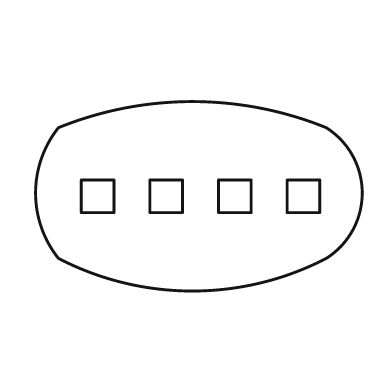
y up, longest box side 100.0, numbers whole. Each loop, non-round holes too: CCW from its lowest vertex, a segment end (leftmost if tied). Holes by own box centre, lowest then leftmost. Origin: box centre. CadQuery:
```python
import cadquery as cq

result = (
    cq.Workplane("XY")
    .moveTo(-43.0, -19.0)
    .threePointArc((-2.0, -29.0), (39.0, -19.0))
    .threePointArc((50.0, 1.0), (39.0, 21.0))
    .threePointArc((-2.0, 29.0), (-43.0, 21.0))
    .threePointArc((-50.0, 1.0), (-43.0, -19.0))
    .close()
    .moveTo(-36.0, -5.0)
    .lineTo(-26.0, -5.0)
    .lineTo(-26.0, 5.0)
    .lineTo(-36.0, 5.0)
    .close()
    .moveTo(-15.0, -5.0)
    .lineTo(-5.0, -5.0)
    .lineTo(-5.0, 5.0)
    .lineTo(-15.0, 5.0)
    .close()
    .moveTo(6.0, -5.0)
    .lineTo(16.0, -5.0)
    .lineTo(16.0, 5.0)
    .lineTo(6.0, 5.0)
    .close()
    .moveTo(27.0, -5.0)
    .lineTo(37.0, -5.0)
    .lineTo(37.0, 5.0)
    .lineTo(27.0, 5.0)
    .close()
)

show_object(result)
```